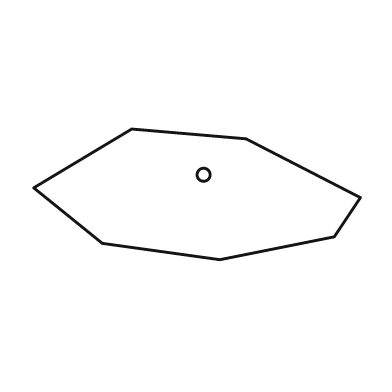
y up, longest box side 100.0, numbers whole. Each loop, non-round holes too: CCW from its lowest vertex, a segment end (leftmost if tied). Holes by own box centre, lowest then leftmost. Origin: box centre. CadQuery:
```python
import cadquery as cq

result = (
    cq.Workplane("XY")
    .moveTo(7.0, -20.0)
    .lineTo(42.0, -13.0)
    .lineTo(50.0, -1.0)
    .lineTo(15.0, 17.0)
    .lineTo(-20.0, 20.0)
    .lineTo(-50.0, 2.0)
    .lineTo(-29.0, -15.0)
    .close()
    .moveTo(2.0, 6.0)
    .circle(2.0)
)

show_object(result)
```